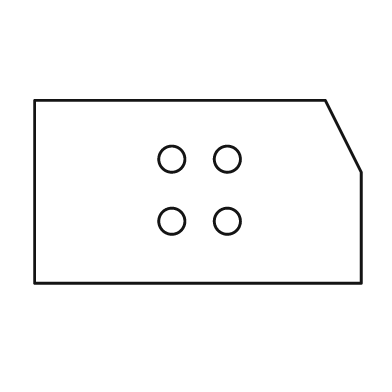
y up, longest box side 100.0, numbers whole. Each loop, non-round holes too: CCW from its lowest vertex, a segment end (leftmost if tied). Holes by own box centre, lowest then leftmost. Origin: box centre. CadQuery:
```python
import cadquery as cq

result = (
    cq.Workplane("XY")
    .moveTo(-50.0, -28.0)
    .lineTo(50.0, -28.0)
    .lineTo(50.0, 6.0)
    .lineTo(39.0, 28.0)
    .lineTo(-50.0, 28.0)
    .close()
    .moveTo(-8.0, -9.0)
    .circle(4.0)
    .moveTo(9.0, -9.0)
    .circle(4.0)
    .moveTo(-8.0, 10.0)
    .circle(4.0)
    .moveTo(9.0, 10.0)
    .circle(4.0)
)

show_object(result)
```